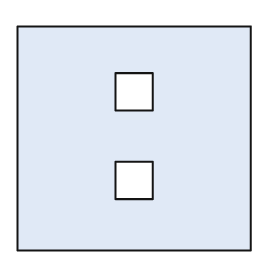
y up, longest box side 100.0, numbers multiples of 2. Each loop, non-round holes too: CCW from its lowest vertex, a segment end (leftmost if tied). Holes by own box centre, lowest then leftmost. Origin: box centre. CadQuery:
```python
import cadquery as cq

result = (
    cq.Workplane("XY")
    .moveTo(-50.0, -48.0)
    .lineTo(50.0, -48.0)
    .lineTo(50.0, 48.0)
    .lineTo(-50.0, 48.0)
    .close()
    .moveTo(-8.0, -26.0)
    .lineTo(8.0, -26.0)
    .lineTo(8.0, -10.0)
    .lineTo(-8.0, -10.0)
    .close()
    .moveTo(-8.0, 12.0)
    .lineTo(8.0, 12.0)
    .lineTo(8.0, 28.0)
    .lineTo(-8.0, 28.0)
    .close()
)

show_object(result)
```